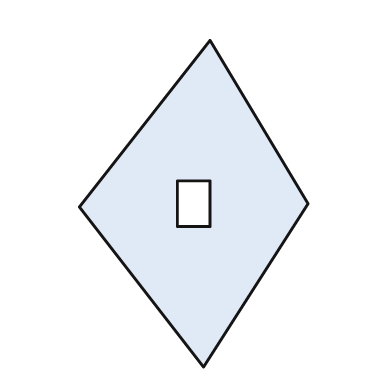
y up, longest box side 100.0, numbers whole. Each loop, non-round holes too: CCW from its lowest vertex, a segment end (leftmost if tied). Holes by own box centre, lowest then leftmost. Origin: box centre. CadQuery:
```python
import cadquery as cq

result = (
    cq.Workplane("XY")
    .moveTo(3.0, -50.0)
    .lineTo(35.0, 0.0)
    .lineTo(5.0, 50.0)
    .lineTo(-35.0, -1.0)
    .close()
    .moveTo(-5.0, -7.0)
    .lineTo(5.0, -7.0)
    .lineTo(5.0, 7.0)
    .lineTo(-5.0, 7.0)
    .close()
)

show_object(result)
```